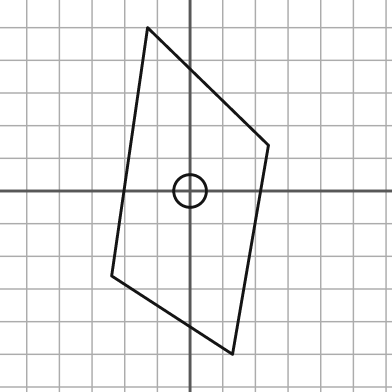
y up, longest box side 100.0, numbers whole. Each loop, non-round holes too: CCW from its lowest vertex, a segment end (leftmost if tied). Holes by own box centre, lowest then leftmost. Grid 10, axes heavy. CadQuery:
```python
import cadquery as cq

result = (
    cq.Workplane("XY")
    .moveTo(13.0, -50.0)
    .lineTo(24.0, 14.0)
    .lineTo(-13.0, 50.0)
    .lineTo(-24.0, -26.0)
    .close()
    .moveTo(0.0, 0.0)
    .circle(5.0)
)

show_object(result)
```